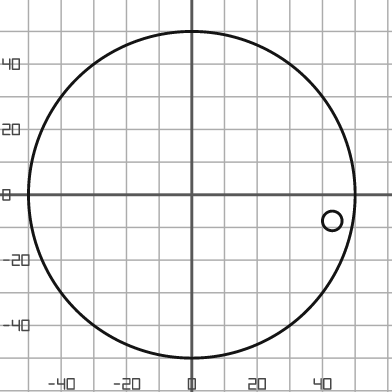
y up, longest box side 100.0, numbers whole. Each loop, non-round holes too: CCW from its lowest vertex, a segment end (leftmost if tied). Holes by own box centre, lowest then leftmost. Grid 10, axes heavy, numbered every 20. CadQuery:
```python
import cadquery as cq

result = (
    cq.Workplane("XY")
    .moveTo(0.0, 0.0)
    .circle(50.0)
    .moveTo(43.0, -8.0)
    .circle(3.0)
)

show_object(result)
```